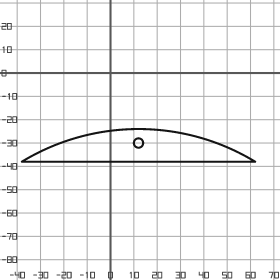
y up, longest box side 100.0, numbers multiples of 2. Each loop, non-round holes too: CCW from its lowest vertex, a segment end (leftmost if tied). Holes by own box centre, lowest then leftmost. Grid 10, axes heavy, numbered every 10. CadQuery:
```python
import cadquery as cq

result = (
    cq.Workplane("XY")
    .moveTo(-38.0, -38.0)
    .lineTo(62.0, -38.0)
    .threePointArc((12.0, -24.0), (-38.0, -38.0))
    .close()
    .moveTo(12.0, -30.0)
    .circle(2.0)
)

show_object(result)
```